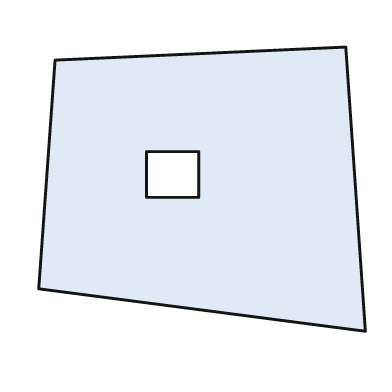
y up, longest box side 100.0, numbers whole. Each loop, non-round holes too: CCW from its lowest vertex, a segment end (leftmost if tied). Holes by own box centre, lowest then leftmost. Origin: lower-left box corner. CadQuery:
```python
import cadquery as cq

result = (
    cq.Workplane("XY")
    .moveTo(100.0, 0.0)
    .lineTo(94.0, 87.0)
    .lineTo(5.0, 83.0)
    .lineTo(0.0, 13.0)
    .close()
    .moveTo(33.0, 41.0)
    .lineTo(49.0, 41.0)
    .lineTo(49.0, 55.0)
    .lineTo(33.0, 55.0)
    .close()
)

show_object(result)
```